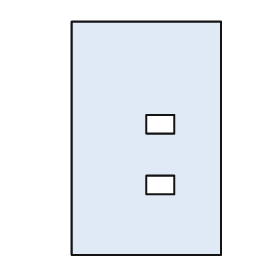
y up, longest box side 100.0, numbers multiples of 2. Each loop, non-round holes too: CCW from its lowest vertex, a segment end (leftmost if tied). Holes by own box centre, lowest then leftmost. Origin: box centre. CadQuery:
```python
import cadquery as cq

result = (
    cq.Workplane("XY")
    .moveTo(-32.0, -50.0)
    .lineTo(32.0, -50.0)
    .lineTo(32.0, 50.0)
    .lineTo(-32.0, 50.0)
    .close()
    .moveTo(0.0, -24.0)
    .lineTo(12.0, -24.0)
    .lineTo(12.0, -16.0)
    .lineTo(0.0, -16.0)
    .close()
    .moveTo(0.0, 2.0)
    .lineTo(12.0, 2.0)
    .lineTo(12.0, 10.0)
    .lineTo(0.0, 10.0)
    .close()
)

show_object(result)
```